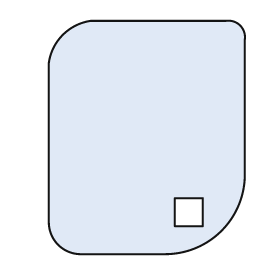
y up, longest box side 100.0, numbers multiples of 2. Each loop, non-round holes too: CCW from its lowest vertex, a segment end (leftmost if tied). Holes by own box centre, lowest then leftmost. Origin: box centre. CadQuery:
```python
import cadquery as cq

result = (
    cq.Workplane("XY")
    .moveTo(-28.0, -50.0)
    .lineTo(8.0, -50.0)
    .threePointArc((32.0, -40.0), (42.0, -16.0))
    .lineTo(42.0, 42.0)
    .threePointArc((40.0, 48.0), (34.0, 50.0))
    .lineTo(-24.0, 50.0)
    .threePointArc((-36.0, 44.0), (-42.0, 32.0))
    .lineTo(-42.0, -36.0)
    .threePointArc((-38.0, -46.0), (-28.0, -50.0))
    .close()
    .moveTo(12.0, -38.0)
    .lineTo(24.0, -38.0)
    .lineTo(24.0, -26.0)
    .lineTo(12.0, -26.0)
    .close()
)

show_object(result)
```